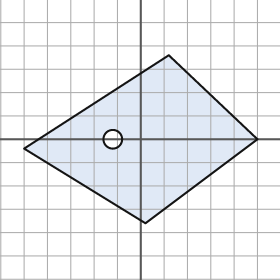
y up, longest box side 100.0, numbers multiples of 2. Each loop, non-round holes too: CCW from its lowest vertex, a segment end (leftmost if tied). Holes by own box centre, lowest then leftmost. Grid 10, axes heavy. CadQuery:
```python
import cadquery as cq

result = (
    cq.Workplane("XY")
    .moveTo(2.0, -36.0)
    .lineTo(50.0, 0.0)
    .lineTo(12.0, 36.0)
    .lineTo(-50.0, -4.0)
    .close()
    .moveTo(-12.0, 0.0)
    .circle(4.0)
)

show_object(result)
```